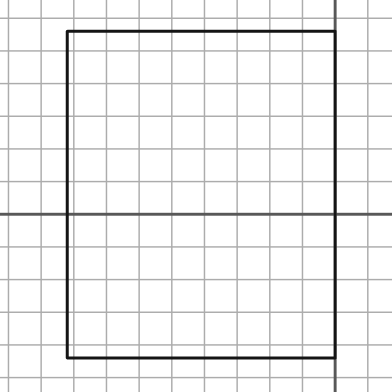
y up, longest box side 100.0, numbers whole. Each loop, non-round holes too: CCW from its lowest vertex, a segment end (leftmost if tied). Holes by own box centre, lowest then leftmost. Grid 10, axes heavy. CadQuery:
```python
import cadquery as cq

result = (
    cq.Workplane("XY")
    .moveTo(-82.0, -44.0)
    .lineTo(0.0, -44.0)
    .lineTo(0.0, 56.0)
    .lineTo(-82.0, 56.0)
    .close()
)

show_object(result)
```